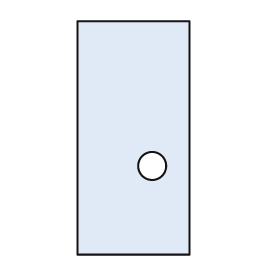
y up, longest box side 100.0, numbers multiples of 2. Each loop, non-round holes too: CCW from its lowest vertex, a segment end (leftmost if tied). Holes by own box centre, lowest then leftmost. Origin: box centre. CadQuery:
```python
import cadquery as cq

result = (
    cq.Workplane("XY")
    .moveTo(-24.0, -50.0)
    .lineTo(24.0, -50.0)
    .lineTo(24.0, 50.0)
    .lineTo(-24.0, 50.0)
    .close()
    .moveTo(8.0, -12.0)
    .circle(6.0)
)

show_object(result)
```